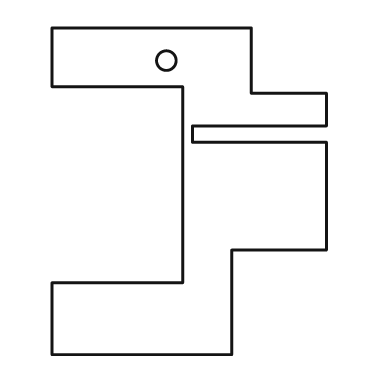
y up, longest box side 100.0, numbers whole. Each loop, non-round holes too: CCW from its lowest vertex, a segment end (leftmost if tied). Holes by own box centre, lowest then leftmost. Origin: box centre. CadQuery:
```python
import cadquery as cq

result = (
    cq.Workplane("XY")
    .moveTo(-42.0, -50.0)
    .lineTo(13.0, -50.0)
    .lineTo(13.0, -18.0)
    .lineTo(42.0, -18.0)
    .lineTo(42.0, 15.0)
    .lineTo(1.0, 15.0)
    .lineTo(1.0, 20.0)
    .lineTo(42.0, 20.0)
    .lineTo(42.0, 30.0)
    .lineTo(19.0, 30.0)
    .lineTo(19.0, 50.0)
    .lineTo(-42.0, 50.0)
    .lineTo(-42.0, 32.0)
    .lineTo(-2.0, 32.0)
    .lineTo(-2.0, -28.0)
    .lineTo(-42.0, -28.0)
    .close()
    .moveTo(-7.0, 40.0)
    .circle(3.0)
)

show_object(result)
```